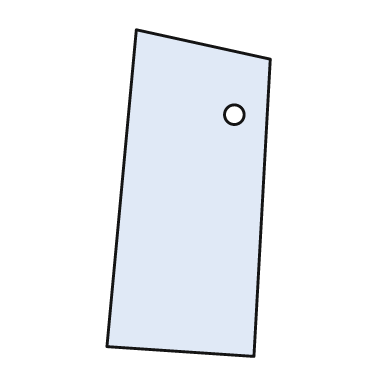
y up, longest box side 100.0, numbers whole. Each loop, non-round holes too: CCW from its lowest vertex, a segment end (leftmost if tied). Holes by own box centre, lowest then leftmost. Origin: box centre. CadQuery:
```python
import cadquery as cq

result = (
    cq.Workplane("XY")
    .moveTo(20.0, -50.0)
    .lineTo(25.0, 41.0)
    .lineTo(-16.0, 50.0)
    .lineTo(-25.0, -47.0)
    .close()
    .moveTo(14.0, 24.0)
    .circle(3.0)
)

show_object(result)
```